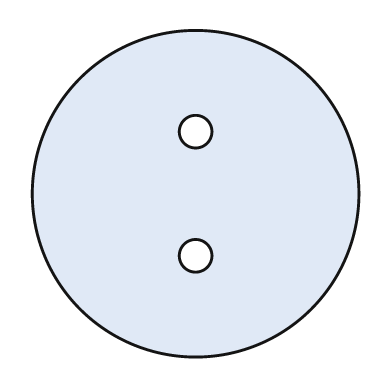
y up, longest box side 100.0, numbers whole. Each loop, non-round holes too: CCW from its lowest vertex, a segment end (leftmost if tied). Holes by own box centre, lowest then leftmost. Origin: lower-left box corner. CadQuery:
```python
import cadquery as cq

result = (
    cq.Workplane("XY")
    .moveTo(50.0, 50.0)
    .circle(50.0)
    .moveTo(50.0, 31.0)
    .circle(5.0)
    .moveTo(50.0, 69.0)
    .circle(5.0)
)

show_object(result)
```